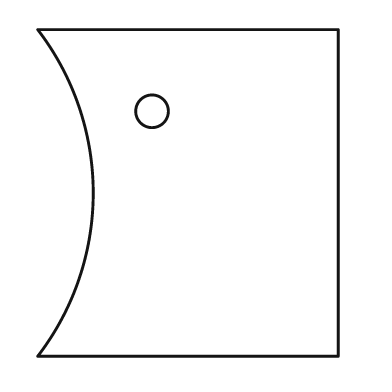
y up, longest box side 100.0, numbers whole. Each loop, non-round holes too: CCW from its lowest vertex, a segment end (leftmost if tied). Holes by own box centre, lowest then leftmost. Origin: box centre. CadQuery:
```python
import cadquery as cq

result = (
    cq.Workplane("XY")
    .moveTo(-46.0, -50.0)
    .lineTo(46.0, -50.0)
    .lineTo(46.0, 50.0)
    .lineTo(-46.0, 50.0)
    .threePointArc((-29.0, 0.0), (-46.0, -50.0))
    .close()
    .moveTo(-11.0, 25.0)
    .circle(5.0)
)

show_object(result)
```